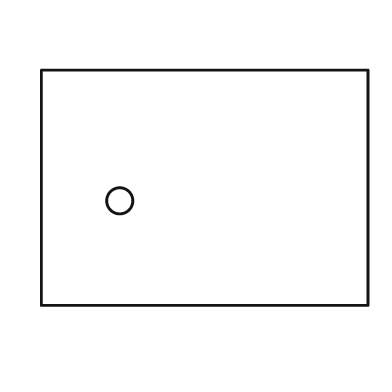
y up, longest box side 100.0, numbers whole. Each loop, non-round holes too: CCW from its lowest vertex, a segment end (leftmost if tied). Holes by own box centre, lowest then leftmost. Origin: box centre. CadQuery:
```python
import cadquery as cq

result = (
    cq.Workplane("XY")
    .moveTo(-50.0, -36.0)
    .lineTo(50.0, -36.0)
    .lineTo(50.0, 36.0)
    .lineTo(-50.0, 36.0)
    .close()
    .moveTo(-26.0, -4.0)
    .circle(4.0)
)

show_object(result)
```